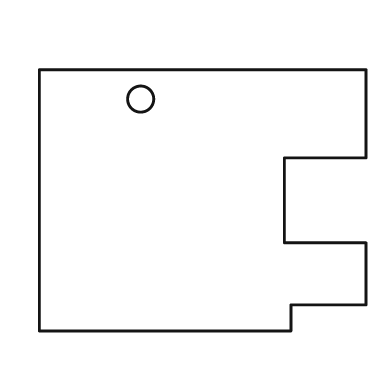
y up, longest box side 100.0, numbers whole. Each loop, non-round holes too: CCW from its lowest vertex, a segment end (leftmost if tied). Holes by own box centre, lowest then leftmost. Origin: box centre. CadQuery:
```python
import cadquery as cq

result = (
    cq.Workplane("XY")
    .moveTo(-50.0, -40.0)
    .lineTo(27.0, -40.0)
    .lineTo(27.0, -32.0)
    .lineTo(50.0, -32.0)
    .lineTo(50.0, -13.0)
    .lineTo(25.0, -13.0)
    .lineTo(25.0, 13.0)
    .lineTo(50.0, 13.0)
    .lineTo(50.0, 40.0)
    .lineTo(-50.0, 40.0)
    .close()
    .moveTo(-19.0, 31.0)
    .circle(4.0)
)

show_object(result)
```